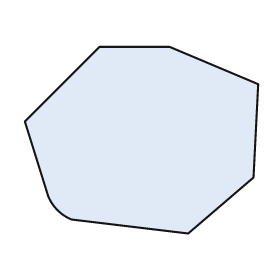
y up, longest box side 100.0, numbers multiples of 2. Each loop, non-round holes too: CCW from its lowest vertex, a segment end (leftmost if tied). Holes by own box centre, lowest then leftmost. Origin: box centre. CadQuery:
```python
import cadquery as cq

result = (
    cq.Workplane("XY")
    .moveTo(20.0, -40.0)
    .lineTo(48.0, -16.0)
    .lineTo(50.0, 24.0)
    .lineTo(12.0, 40.0)
    .lineTo(-18.0, 40.0)
    .lineTo(-50.0, 8.0)
    .lineTo(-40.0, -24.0)
    .threePointArc((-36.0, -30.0), (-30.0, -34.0))
    .close()
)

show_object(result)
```